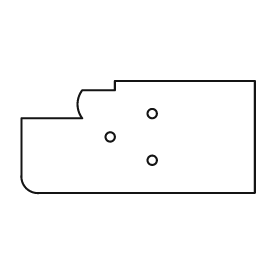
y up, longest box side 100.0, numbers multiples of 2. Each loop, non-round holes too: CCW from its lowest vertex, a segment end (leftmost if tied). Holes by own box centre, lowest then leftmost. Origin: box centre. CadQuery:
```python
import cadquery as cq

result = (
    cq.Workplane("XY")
    .moveTo(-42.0, -24.0)
    .lineTo(50.0, -24.0)
    .lineTo(50.0, 24.0)
    .lineTo(-10.0, 24.0)
    .lineTo(-10.0, 20.0)
    .lineTo(-24.0, 20.0)
    .threePointArc((-26.0, 14.0), (-24.0, 8.0))
    .lineTo(-50.0, 8.0)
    .lineTo(-50.0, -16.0)
    .threePointArc((-48.0, -22.0), (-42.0, -24.0))
    .close()
    .moveTo(6.0, -10.0)
    .circle(2.0)
    .moveTo(-12.0, 0.0)
    .circle(2.0)
    .moveTo(6.0, 10.0)
    .circle(2.0)
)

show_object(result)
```